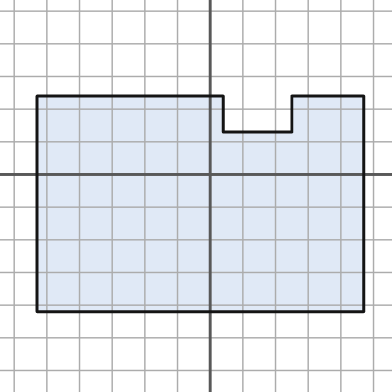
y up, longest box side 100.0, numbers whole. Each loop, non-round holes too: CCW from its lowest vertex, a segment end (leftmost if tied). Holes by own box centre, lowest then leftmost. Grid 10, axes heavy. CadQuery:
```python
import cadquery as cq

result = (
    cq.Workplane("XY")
    .moveTo(-53.0, -42.0)
    .lineTo(47.0, -42.0)
    .lineTo(47.0, 24.0)
    .lineTo(25.0, 24.0)
    .lineTo(25.0, 13.0)
    .lineTo(4.0, 13.0)
    .lineTo(4.0, 24.0)
    .lineTo(-53.0, 24.0)
    .close()
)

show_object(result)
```